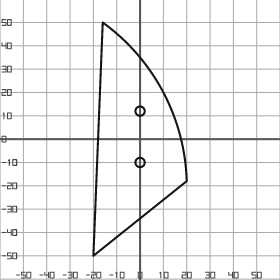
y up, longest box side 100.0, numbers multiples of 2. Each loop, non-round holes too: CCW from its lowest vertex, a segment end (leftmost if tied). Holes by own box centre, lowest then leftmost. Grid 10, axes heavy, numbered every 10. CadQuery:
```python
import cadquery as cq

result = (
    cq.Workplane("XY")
    .moveTo(-20.0, -50.0)
    .lineTo(20.0, -18.0)
    .threePointArc((10.0, 20.0), (-16.0, 50.0))
    .close()
    .moveTo(0.0, -10.0)
    .circle(2.0)
    .moveTo(0.0, 12.0)
    .circle(2.0)
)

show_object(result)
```